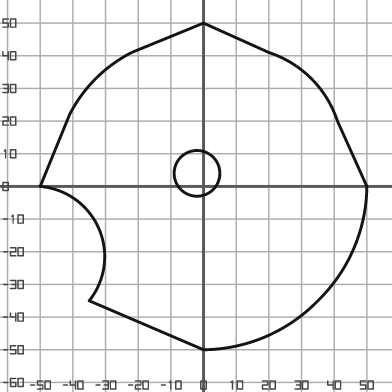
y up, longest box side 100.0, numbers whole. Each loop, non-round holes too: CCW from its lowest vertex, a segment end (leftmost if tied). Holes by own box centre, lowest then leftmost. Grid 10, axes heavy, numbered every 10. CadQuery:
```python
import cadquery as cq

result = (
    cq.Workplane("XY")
    .moveTo(0.0, -50.0)
    .threePointArc((19.0, -46.0), (35.0, -35.0))
    .threePointArc((46.0, -19.0), (50.0, 0.0))
    .lineTo(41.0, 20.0)
    .threePointArc((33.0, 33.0), (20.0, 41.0))
    .lineTo(0.0, 50.0)
    .lineTo(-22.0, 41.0)
    .threePointArc((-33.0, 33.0), (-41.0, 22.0))
    .lineTo(-50.0, 0.0)
    .threePointArc((-32.0, -13.0), (-35.0, -35.0))
    .close()
    .moveTo(-2.0, 4.0)
    .circle(7.0)
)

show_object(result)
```